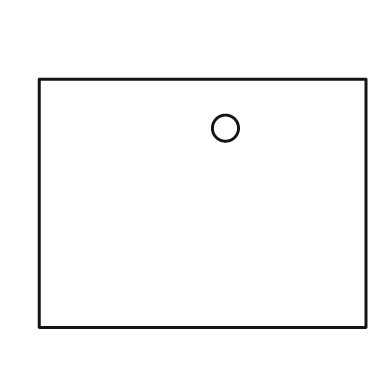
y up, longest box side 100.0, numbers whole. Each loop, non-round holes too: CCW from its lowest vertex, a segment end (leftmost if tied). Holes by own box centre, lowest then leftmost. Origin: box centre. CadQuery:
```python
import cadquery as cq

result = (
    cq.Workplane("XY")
    .moveTo(-50.0, -38.0)
    .lineTo(50.0, -38.0)
    .lineTo(50.0, 38.0)
    .lineTo(-50.0, 38.0)
    .close()
    .moveTo(7.0, 23.0)
    .circle(4.0)
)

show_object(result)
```